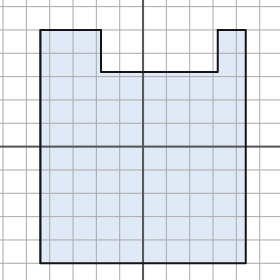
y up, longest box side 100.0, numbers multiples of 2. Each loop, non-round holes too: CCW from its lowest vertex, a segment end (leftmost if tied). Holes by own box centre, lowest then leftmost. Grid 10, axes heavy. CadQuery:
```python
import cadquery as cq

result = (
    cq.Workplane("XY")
    .moveTo(-44.0, -50.0)
    .lineTo(44.0, -50.0)
    .lineTo(44.0, 50.0)
    .lineTo(32.0, 50.0)
    .lineTo(32.0, 32.0)
    .lineTo(-18.0, 32.0)
    .lineTo(-18.0, 50.0)
    .lineTo(-44.0, 50.0)
    .close()
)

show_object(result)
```